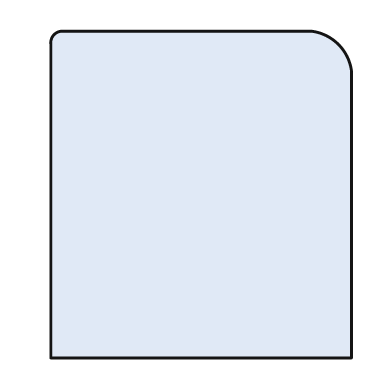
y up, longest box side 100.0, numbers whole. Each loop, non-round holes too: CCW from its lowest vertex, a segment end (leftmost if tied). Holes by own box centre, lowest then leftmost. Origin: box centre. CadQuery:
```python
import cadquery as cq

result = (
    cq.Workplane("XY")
    .moveTo(-46.0, -50.0)
    .lineTo(46.0, -50.0)
    .lineTo(46.0, 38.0)
    .threePointArc((42.0, 46.0), (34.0, 50.0))
    .lineTo(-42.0, 50.0)
    .threePointArc((-45.0, 49.0), (-46.0, 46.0))
    .close()
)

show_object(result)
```